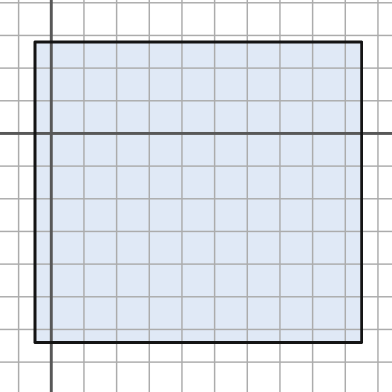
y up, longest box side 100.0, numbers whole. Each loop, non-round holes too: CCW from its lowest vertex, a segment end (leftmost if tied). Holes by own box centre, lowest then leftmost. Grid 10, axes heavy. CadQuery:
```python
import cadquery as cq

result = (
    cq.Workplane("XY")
    .moveTo(-5.0, -64.0)
    .lineTo(95.0, -64.0)
    .lineTo(95.0, 28.0)
    .lineTo(-5.0, 28.0)
    .close()
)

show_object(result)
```